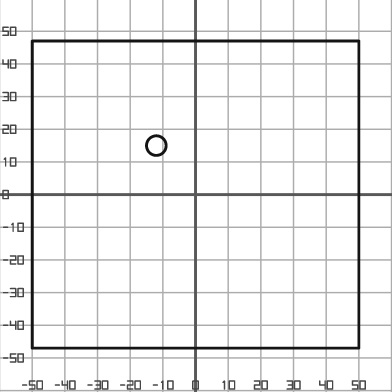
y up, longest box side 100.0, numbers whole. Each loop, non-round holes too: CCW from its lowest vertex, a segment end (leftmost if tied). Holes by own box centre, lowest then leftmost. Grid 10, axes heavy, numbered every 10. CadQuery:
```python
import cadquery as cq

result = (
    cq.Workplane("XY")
    .moveTo(-50.0, -47.0)
    .lineTo(50.0, -47.0)
    .lineTo(50.0, 47.0)
    .lineTo(-50.0, 47.0)
    .close()
    .moveTo(-12.0, 15.0)
    .circle(3.0)
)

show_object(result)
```